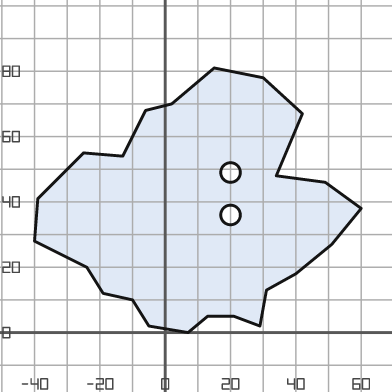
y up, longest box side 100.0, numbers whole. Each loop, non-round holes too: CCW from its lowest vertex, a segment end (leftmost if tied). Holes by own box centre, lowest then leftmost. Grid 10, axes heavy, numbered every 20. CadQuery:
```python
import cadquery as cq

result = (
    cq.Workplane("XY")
    .moveTo(7.0, 0.0)
    .lineTo(13.0, 5.0)
    .lineTo(21.0, 5.0)
    .lineTo(29.0, 2.0)
    .lineTo(31.0, 13.0)
    .lineTo(40.0, 18.0)
    .lineTo(51.0, 27.0)
    .lineTo(60.0, 38.0)
    .lineTo(49.0, 46.0)
    .lineTo(34.0, 48.0)
    .lineTo(42.0, 67.0)
    .lineTo(30.0, 78.0)
    .lineTo(15.0, 81.0)
    .lineTo(2.0, 70.0)
    .lineTo(-6.0, 68.0)
    .lineTo(-13.0, 54.0)
    .lineTo(-25.0, 55.0)
    .lineTo(-39.0, 41.0)
    .lineTo(-40.0, 28.0)
    .lineTo(-24.0, 20.0)
    .lineTo(-19.0, 12.0)
    .lineTo(-10.0, 10.0)
    .lineTo(-5.0, 2.0)
    .close()
    .moveTo(20.0, 36.0)
    .circle(3.0)
    .moveTo(20.0, 49.0)
    .circle(3.0)
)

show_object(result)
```